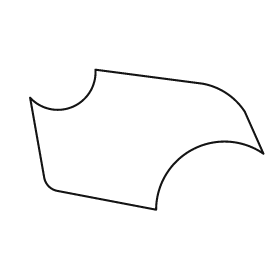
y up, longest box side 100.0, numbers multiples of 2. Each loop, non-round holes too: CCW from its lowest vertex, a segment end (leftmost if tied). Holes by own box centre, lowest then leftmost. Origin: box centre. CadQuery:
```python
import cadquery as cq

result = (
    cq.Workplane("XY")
    .moveTo(4.0, -30.0)
    .threePointArc((20.0, -4.0), (50.0, -6.0))
    .lineTo(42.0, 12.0)
    .threePointArc((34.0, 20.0), (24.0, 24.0))
    .lineTo(-22.0, 30.0)
    .threePointArc((-32.0, 14.0), (-50.0, 18.0))
    .lineTo(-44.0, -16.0)
    .threePointArc((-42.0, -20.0), (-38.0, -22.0))
    .close()
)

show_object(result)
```